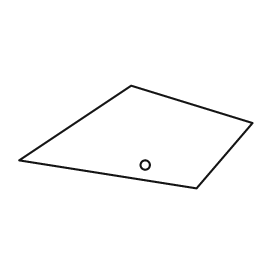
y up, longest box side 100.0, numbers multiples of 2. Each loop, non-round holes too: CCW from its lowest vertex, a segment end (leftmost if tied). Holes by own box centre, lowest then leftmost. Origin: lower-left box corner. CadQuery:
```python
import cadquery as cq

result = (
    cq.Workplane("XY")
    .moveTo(76.0, 0.0)
    .lineTo(100.0, 28.0)
    .lineTo(48.0, 44.0)
    .lineTo(0.0, 12.0)
    .close()
    .moveTo(54.0, 10.0)
    .circle(2.0)
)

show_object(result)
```